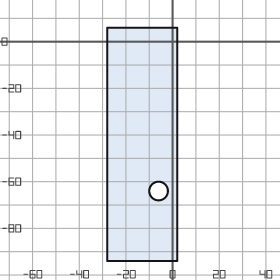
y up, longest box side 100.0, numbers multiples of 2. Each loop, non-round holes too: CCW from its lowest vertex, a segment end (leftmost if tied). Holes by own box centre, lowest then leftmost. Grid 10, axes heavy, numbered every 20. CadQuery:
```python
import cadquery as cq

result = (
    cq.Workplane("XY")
    .moveTo(-28.0, -94.0)
    .lineTo(2.0, -94.0)
    .lineTo(2.0, 6.0)
    .lineTo(-28.0, 6.0)
    .close()
    .moveTo(-6.0, -64.0)
    .circle(4.0)
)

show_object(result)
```